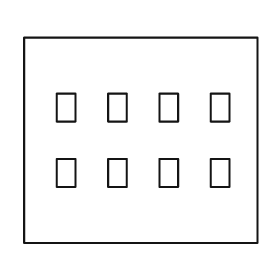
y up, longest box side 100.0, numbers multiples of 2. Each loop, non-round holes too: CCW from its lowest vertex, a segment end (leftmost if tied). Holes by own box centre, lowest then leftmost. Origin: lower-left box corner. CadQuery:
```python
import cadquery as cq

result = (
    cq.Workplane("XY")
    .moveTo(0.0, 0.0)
    .lineTo(100.0, 0.0)
    .lineTo(100.0, 88.0)
    .lineTo(0.0, 88.0)
    .close()
    .moveTo(14.0, 24.0)
    .lineTo(22.0, 24.0)
    .lineTo(22.0, 36.0)
    .lineTo(14.0, 36.0)
    .close()
    .moveTo(36.0, 24.0)
    .lineTo(44.0, 24.0)
    .lineTo(44.0, 36.0)
    .lineTo(36.0, 36.0)
    .close()
    .moveTo(58.0, 24.0)
    .lineTo(66.0, 24.0)
    .lineTo(66.0, 36.0)
    .lineTo(58.0, 36.0)
    .close()
    .moveTo(80.0, 24.0)
    .lineTo(88.0, 24.0)
    .lineTo(88.0, 36.0)
    .lineTo(80.0, 36.0)
    .close()
    .moveTo(14.0, 52.0)
    .lineTo(22.0, 52.0)
    .lineTo(22.0, 64.0)
    .lineTo(14.0, 64.0)
    .close()
    .moveTo(36.0, 52.0)
    .lineTo(44.0, 52.0)
    .lineTo(44.0, 64.0)
    .lineTo(36.0, 64.0)
    .close()
    .moveTo(58.0, 52.0)
    .lineTo(66.0, 52.0)
    .lineTo(66.0, 64.0)
    .lineTo(58.0, 64.0)
    .close()
    .moveTo(80.0, 52.0)
    .lineTo(88.0, 52.0)
    .lineTo(88.0, 64.0)
    .lineTo(80.0, 64.0)
    .close()
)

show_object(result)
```